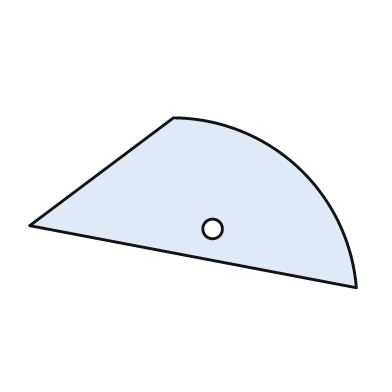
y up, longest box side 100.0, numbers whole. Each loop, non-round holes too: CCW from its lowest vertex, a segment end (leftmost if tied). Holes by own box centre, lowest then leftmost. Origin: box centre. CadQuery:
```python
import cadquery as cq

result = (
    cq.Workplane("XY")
    .moveTo(50.0, -26.0)
    .threePointArc((32.0, 11.0), (-6.0, 26.0))
    .lineTo(-50.0, -7.0)
    .close()
    .moveTo(6.0, -8.0)
    .circle(3.0)
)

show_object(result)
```